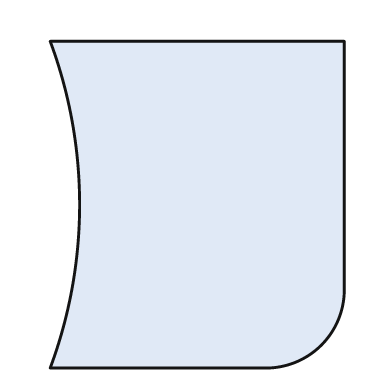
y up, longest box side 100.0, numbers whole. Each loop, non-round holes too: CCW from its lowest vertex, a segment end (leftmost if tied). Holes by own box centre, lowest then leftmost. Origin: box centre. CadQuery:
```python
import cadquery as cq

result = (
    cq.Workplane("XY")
    .moveTo(-45.0, -50.0)
    .lineTo(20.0, -50.0)
    .threePointArc((38.0, -43.0), (45.0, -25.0))
    .lineTo(45.0, 50.0)
    .lineTo(-45.0, 50.0)
    .threePointArc((-36.0, 0.0), (-45.0, -50.0))
    .close()
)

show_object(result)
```